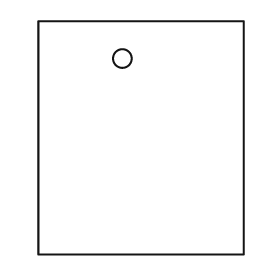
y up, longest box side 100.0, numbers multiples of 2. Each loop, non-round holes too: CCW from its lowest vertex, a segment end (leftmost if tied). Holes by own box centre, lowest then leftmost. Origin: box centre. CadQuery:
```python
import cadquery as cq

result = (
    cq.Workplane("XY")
    .moveTo(-44.0, -50.0)
    .lineTo(44.0, -50.0)
    .lineTo(44.0, 50.0)
    .lineTo(-44.0, 50.0)
    .close()
    .moveTo(-8.0, 34.0)
    .circle(4.0)
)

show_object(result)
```